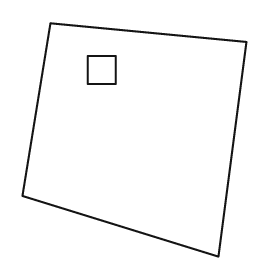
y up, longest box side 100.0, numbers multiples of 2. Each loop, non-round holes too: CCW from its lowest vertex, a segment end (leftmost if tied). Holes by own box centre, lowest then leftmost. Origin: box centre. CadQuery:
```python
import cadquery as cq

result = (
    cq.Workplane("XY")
    .moveTo(36.0, -50.0)
    .lineTo(48.0, 42.0)
    .lineTo(-36.0, 50.0)
    .lineTo(-48.0, -24.0)
    .close()
    .moveTo(-20.0, 24.0)
    .lineTo(-8.0, 24.0)
    .lineTo(-8.0, 36.0)
    .lineTo(-20.0, 36.0)
    .close()
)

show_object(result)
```